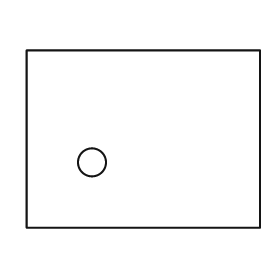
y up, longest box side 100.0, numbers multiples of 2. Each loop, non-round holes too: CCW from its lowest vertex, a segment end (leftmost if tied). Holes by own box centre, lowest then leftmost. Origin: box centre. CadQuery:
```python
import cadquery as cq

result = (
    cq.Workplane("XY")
    .moveTo(-50.0, -38.0)
    .lineTo(50.0, -38.0)
    .lineTo(50.0, 38.0)
    .lineTo(-50.0, 38.0)
    .close()
    .moveTo(-22.0, -10.0)
    .circle(6.0)
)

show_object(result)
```